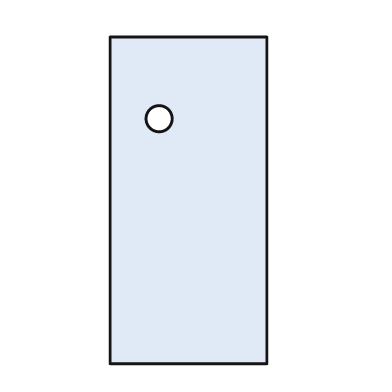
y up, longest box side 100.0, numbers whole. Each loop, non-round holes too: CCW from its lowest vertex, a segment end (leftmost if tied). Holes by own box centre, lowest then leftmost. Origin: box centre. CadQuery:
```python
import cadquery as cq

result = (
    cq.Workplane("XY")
    .moveTo(-24.0, -50.0)
    .lineTo(24.0, -50.0)
    .lineTo(24.0, 50.0)
    .lineTo(-24.0, 50.0)
    .close()
    .moveTo(-9.0, 25.0)
    .circle(4.0)
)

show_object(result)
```